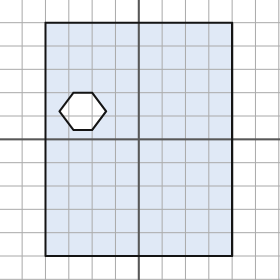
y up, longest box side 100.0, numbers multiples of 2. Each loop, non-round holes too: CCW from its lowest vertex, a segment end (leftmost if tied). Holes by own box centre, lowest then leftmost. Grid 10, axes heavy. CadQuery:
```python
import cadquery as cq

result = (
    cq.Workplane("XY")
    .moveTo(-40.0, -50.0)
    .lineTo(40.0, -50.0)
    .lineTo(40.0, 50.0)
    .lineTo(-40.0, 50.0)
    .close()
    .moveTo(-28.0, 4.0)
    .lineTo(-20.0, 4.0)
    .lineTo(-14.0, 12.0)
    .lineTo(-20.0, 20.0)
    .lineTo(-28.0, 20.0)
    .lineTo(-34.0, 12.0)
    .close()
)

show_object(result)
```